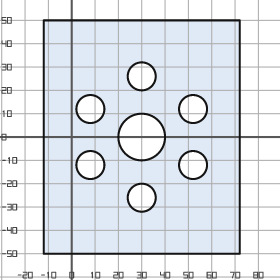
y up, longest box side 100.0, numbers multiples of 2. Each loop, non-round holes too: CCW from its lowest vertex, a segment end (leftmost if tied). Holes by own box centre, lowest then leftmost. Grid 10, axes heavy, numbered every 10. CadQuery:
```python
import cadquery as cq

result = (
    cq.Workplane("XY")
    .moveTo(-12.0, -50.0)
    .lineTo(72.0, -50.0)
    .lineTo(72.0, 50.0)
    .lineTo(-12.0, 50.0)
    .close()
    .moveTo(30.0, -26.0)
    .circle(6.0)
    .moveTo(8.0, -12.0)
    .circle(6.0)
    .moveTo(52.0, -12.0)
    .circle(6.0)
    .moveTo(30.0, 0.0)
    .circle(10.0)
    .moveTo(8.0, 12.0)
    .circle(6.0)
    .moveTo(52.0, 12.0)
    .circle(6.0)
    .moveTo(30.0, 26.0)
    .circle(6.0)
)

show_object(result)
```